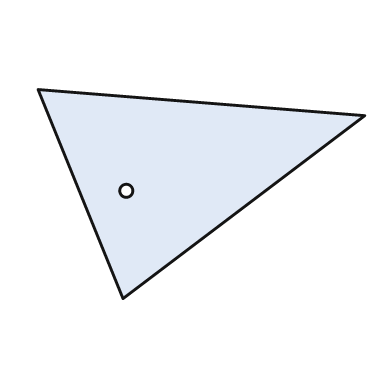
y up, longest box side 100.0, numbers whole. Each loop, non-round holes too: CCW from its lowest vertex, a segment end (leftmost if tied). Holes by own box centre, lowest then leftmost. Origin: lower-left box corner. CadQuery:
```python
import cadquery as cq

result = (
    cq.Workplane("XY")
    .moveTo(26.0, 0.0)
    .lineTo(100.0, 56.0)
    .lineTo(0.0, 64.0)
    .close()
    .moveTo(27.0, 33.0)
    .circle(2.0)
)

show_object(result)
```